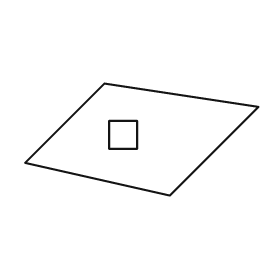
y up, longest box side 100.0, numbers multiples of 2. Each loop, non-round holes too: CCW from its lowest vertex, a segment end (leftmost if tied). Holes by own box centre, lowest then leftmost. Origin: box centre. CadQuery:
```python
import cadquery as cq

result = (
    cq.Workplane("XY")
    .moveTo(12.0, -24.0)
    .lineTo(50.0, 14.0)
    .lineTo(-16.0, 24.0)
    .lineTo(-50.0, -10.0)
    .close()
    .moveTo(-14.0, -4.0)
    .lineTo(-2.0, -4.0)
    .lineTo(-2.0, 8.0)
    .lineTo(-14.0, 8.0)
    .close()
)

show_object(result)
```